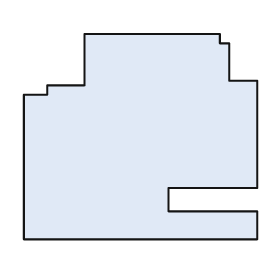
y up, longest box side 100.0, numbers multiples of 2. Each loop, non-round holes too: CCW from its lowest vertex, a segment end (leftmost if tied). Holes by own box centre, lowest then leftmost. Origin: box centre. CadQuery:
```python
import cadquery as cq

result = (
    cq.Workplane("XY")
    .moveTo(-50.0, -44.0)
    .lineTo(50.0, -44.0)
    .lineTo(50.0, -32.0)
    .lineTo(12.0, -32.0)
    .lineTo(12.0, -22.0)
    .lineTo(50.0, -22.0)
    .lineTo(50.0, 24.0)
    .lineTo(38.0, 24.0)
    .lineTo(38.0, 40.0)
    .lineTo(34.0, 40.0)
    .lineTo(34.0, 44.0)
    .lineTo(-24.0, 44.0)
    .lineTo(-24.0, 22.0)
    .lineTo(-40.0, 22.0)
    .lineTo(-40.0, 18.0)
    .lineTo(-50.0, 18.0)
    .close()
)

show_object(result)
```